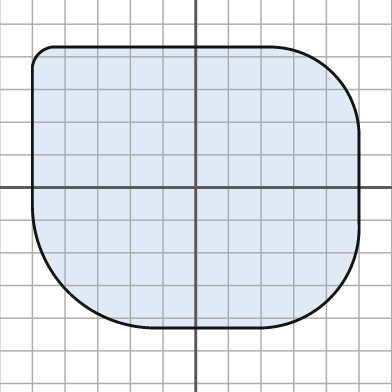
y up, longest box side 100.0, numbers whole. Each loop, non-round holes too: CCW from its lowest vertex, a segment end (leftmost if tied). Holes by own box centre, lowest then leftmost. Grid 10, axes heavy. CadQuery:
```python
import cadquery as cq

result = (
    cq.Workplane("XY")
    .moveTo(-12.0, -43.0)
    .lineTo(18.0, -43.0)
    .threePointArc((41.0, -34.0), (50.0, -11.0))
    .lineTo(50.0, 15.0)
    .threePointArc((42.0, 35.0), (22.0, 43.0))
    .lineTo(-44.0, 43.0)
    .threePointArc((-48.0, 41.0), (-50.0, 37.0))
    .lineTo(-50.0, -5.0)
    .threePointArc((-39.0, -32.0), (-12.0, -43.0))
    .close()
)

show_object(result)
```